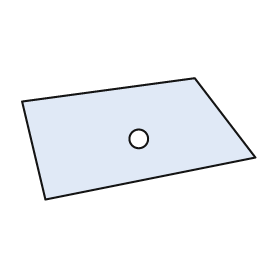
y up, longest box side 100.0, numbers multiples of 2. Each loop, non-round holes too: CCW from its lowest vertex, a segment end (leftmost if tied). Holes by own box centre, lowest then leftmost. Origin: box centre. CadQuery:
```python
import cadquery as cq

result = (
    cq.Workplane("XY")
    .moveTo(-40.0, -26.0)
    .lineTo(50.0, -8.0)
    .lineTo(24.0, 26.0)
    .lineTo(-50.0, 16.0)
    .close()
    .moveTo(0.0, 0.0)
    .circle(4.0)
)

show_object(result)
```